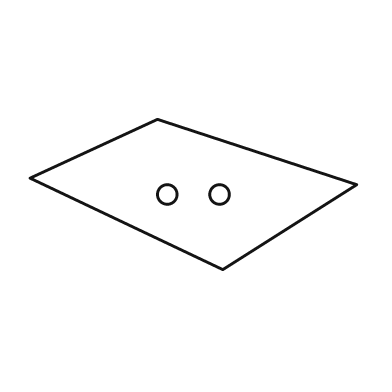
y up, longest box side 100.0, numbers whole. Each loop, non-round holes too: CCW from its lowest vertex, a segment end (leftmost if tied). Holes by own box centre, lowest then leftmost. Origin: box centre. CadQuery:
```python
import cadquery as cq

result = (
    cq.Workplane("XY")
    .moveTo(9.0, -23.0)
    .lineTo(50.0, 3.0)
    .lineTo(-11.0, 23.0)
    .lineTo(-50.0, 5.0)
    .close()
    .moveTo(-8.0, 0.0)
    .circle(3.0)
    .moveTo(8.0, 0.0)
    .circle(3.0)
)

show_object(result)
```